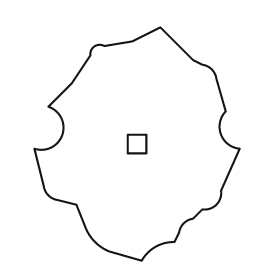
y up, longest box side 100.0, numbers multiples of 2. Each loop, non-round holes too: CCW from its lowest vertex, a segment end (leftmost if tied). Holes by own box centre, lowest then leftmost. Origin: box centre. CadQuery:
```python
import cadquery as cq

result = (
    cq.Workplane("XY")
    .moveTo(2.0, -50.0)
    .threePointArc((8.0, -44.0), (16.0, -42.0))
    .lineTo(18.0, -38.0)
    .threePointArc((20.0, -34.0), (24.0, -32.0))
    .lineTo(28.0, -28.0)
    .threePointArc((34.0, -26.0), (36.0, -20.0))
    .lineTo(44.0, -2.0)
    .threePointArc((36.0, 4.0), (38.0, 14.0))
    .lineTo(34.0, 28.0)
    .threePointArc((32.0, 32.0), (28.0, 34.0))
    .lineTo(24.0, 36.0)
    .lineTo(10.0, 50.0)
    .lineTo(-2.0, 44.0)
    .lineTo(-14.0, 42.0)
    .threePointArc((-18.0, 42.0), (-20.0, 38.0))
    .lineTo(-28.0, 26.0)
    .lineTo(-38.0, 16.0)
    .threePointArc((-32.0, 4.0), (-44.0, -2.0))
    .lineTo(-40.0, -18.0)
    .threePointArc((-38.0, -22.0), (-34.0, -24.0))
    .lineTo(-26.0, -26.0)
    .lineTo(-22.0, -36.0)
    .threePointArc((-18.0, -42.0), (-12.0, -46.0))
    .close()
    .moveTo(-4.0, -4.0)
    .lineTo(4.0, -4.0)
    .lineTo(4.0, 4.0)
    .lineTo(-4.0, 4.0)
    .close()
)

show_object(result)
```